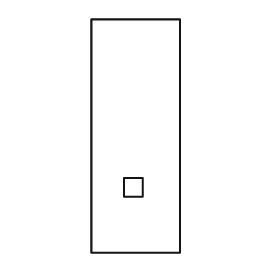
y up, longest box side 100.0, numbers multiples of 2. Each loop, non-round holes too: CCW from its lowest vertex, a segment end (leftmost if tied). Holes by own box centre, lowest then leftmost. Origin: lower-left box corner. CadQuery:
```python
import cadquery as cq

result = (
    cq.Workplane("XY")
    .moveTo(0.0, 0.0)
    .lineTo(38.0, 0.0)
    .lineTo(38.0, 100.0)
    .lineTo(0.0, 100.0)
    .close()
    .moveTo(14.0, 24.0)
    .lineTo(22.0, 24.0)
    .lineTo(22.0, 32.0)
    .lineTo(14.0, 32.0)
    .close()
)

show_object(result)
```